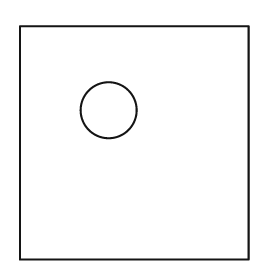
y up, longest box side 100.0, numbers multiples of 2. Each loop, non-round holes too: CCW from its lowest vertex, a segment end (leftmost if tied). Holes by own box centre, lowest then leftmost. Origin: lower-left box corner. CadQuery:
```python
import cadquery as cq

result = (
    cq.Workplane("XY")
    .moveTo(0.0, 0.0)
    .lineTo(98.0, 0.0)
    .lineTo(98.0, 100.0)
    .lineTo(0.0, 100.0)
    .close()
    .moveTo(38.0, 64.0)
    .circle(12.0)
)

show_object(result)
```